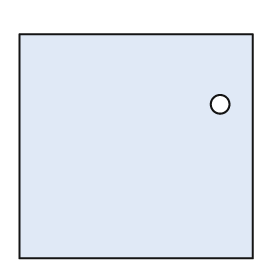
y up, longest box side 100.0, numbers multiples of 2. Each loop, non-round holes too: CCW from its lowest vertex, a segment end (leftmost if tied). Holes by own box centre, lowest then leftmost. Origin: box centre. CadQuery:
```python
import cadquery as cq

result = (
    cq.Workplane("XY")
    .moveTo(-50.0, -48.0)
    .lineTo(50.0, -48.0)
    .lineTo(50.0, 48.0)
    .lineTo(-50.0, 48.0)
    .close()
    .moveTo(36.0, 18.0)
    .circle(4.0)
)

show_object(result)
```